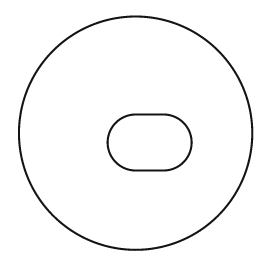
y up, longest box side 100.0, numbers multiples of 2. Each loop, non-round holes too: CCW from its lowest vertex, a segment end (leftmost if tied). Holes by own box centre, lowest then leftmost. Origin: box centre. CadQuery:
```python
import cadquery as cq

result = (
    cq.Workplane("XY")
    .moveTo(0.0, 0.0)
    .circle(50.0)
    .moveTo(0.0, -16.0)
    .lineTo(12.0, -16.0)
    .threePointArc((24.0, -4.0), (12.0, 8.0))
    .lineTo(0.0, 8.0)
    .threePointArc((-12.0, -4.0), (0.0, -16.0))
    .close()
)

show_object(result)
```